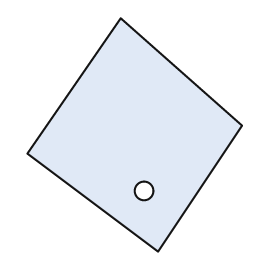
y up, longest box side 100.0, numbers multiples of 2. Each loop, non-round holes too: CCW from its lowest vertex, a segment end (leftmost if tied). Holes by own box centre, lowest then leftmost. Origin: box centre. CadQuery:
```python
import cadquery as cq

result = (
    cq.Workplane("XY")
    .moveTo(10.0, -50.0)
    .lineTo(46.0, 4.0)
    .lineTo(-6.0, 50.0)
    .lineTo(-46.0, -8.0)
    .close()
    .moveTo(4.0, -24.0)
    .circle(4.0)
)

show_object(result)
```